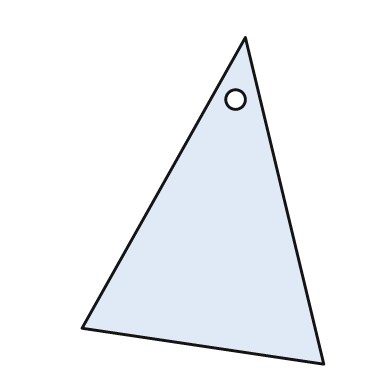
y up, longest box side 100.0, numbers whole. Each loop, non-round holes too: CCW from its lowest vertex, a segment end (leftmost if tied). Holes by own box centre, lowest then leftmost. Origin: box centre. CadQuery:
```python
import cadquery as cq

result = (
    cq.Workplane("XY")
    .moveTo(37.0, -50.0)
    .lineTo(13.0, 50.0)
    .lineTo(-37.0, -39.0)
    .close()
    .moveTo(10.0, 31.0)
    .circle(3.0)
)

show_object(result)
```